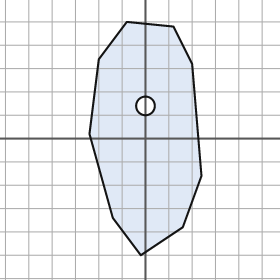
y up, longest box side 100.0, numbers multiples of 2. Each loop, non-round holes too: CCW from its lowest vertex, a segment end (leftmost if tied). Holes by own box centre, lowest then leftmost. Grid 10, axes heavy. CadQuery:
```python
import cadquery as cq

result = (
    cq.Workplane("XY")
    .moveTo(-2.0, -50.0)
    .lineTo(16.0, -38.0)
    .lineTo(24.0, -16.0)
    .lineTo(20.0, 32.0)
    .lineTo(12.0, 48.0)
    .lineTo(-8.0, 50.0)
    .lineTo(-20.0, 34.0)
    .lineTo(-24.0, 2.0)
    .lineTo(-14.0, -34.0)
    .close()
    .moveTo(0.0, 14.0)
    .circle(4.0)
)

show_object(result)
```